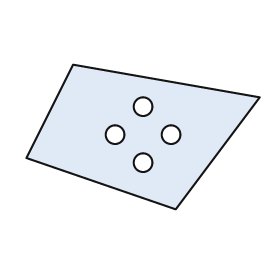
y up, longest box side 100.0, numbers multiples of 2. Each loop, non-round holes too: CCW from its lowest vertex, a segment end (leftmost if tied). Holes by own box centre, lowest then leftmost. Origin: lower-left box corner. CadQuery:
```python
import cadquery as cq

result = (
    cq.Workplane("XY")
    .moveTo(64.0, 0.0)
    .lineTo(100.0, 48.0)
    .lineTo(20.0, 62.0)
    .lineTo(0.0, 22.0)
    .close()
    .moveTo(50.0, 20.0)
    .circle(4.0)
    .moveTo(38.0, 32.0)
    .circle(4.0)
    .moveTo(62.0, 32.0)
    .circle(4.0)
    .moveTo(50.0, 44.0)
    .circle(4.0)
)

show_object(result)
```